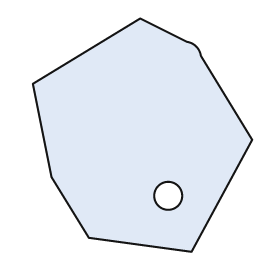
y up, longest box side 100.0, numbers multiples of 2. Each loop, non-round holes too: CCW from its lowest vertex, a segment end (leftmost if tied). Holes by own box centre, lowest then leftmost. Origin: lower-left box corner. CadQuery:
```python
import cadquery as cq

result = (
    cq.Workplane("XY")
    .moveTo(68.0, 0.0)
    .lineTo(94.0, 48.0)
    .lineTo(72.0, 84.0)
    .threePointArc((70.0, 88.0), (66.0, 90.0))
    .lineTo(46.0, 100.0)
    .lineTo(0.0, 72.0)
    .lineTo(8.0, 32.0)
    .lineTo(24.0, 6.0)
    .close()
    .moveTo(58.0, 24.0)
    .circle(6.0)
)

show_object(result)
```